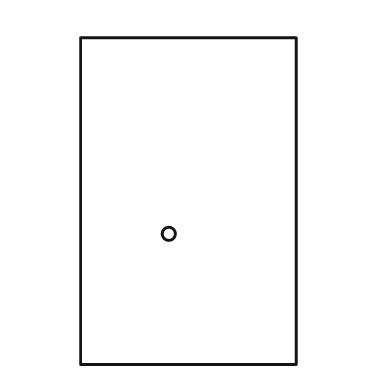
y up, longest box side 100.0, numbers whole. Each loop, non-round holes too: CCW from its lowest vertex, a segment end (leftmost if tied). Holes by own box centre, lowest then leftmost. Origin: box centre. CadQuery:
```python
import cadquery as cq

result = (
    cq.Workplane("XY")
    .moveTo(-33.0, -50.0)
    .lineTo(33.0, -50.0)
    .lineTo(33.0, 50.0)
    .lineTo(-33.0, 50.0)
    .close()
    .moveTo(-6.0, -10.0)
    .circle(2.0)
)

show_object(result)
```